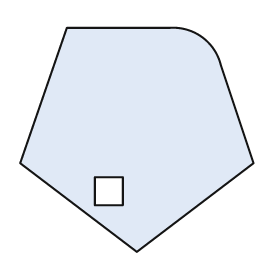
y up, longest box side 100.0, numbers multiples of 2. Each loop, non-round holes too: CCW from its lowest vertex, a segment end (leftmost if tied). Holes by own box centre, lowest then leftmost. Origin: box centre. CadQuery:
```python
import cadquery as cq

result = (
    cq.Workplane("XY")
    .moveTo(0.0, -48.0)
    .lineTo(50.0, -10.0)
    .lineTo(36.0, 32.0)
    .threePointArc((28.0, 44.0), (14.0, 48.0))
    .lineTo(-30.0, 48.0)
    .lineTo(-50.0, -10.0)
    .close()
    .moveTo(-18.0, -28.0)
    .lineTo(-6.0, -28.0)
    .lineTo(-6.0, -16.0)
    .lineTo(-18.0, -16.0)
    .close()
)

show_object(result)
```